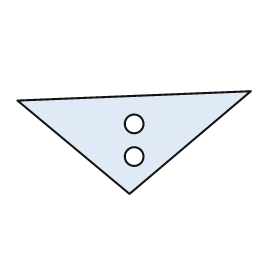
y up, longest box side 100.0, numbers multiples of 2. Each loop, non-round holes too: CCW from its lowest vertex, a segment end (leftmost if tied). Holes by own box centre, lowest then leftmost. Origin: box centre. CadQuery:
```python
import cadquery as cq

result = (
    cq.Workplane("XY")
    .moveTo(-2.0, -22.0)
    .lineTo(50.0, 22.0)
    .lineTo(-50.0, 18.0)
    .close()
    .moveTo(0.0, -6.0)
    .circle(4.0)
    .moveTo(0.0, 8.0)
    .circle(4.0)
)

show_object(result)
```